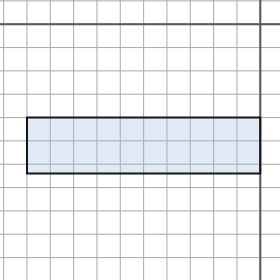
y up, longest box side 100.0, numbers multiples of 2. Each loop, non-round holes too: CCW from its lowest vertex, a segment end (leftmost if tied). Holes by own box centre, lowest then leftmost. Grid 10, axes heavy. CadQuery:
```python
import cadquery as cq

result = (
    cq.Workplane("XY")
    .moveTo(-100.0, -64.0)
    .lineTo(0.0, -64.0)
    .lineTo(0.0, -40.0)
    .lineTo(-100.0, -40.0)
    .close()
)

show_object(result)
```